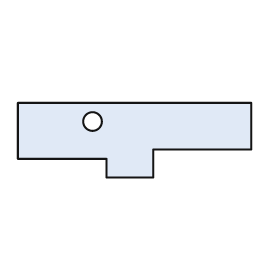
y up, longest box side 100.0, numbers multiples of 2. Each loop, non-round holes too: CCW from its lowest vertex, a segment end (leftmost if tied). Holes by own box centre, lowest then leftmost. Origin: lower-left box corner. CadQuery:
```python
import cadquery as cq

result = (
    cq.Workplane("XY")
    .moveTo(38.0, 0.0)
    .lineTo(58.0, 0.0)
    .lineTo(58.0, 12.0)
    .lineTo(100.0, 12.0)
    .lineTo(100.0, 32.0)
    .lineTo(0.0, 32.0)
    .lineTo(0.0, 8.0)
    .lineTo(38.0, 8.0)
    .close()
    .moveTo(32.0, 24.0)
    .circle(4.0)
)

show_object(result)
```